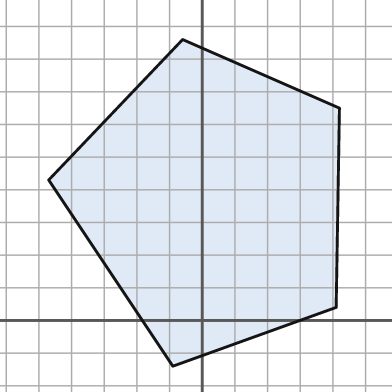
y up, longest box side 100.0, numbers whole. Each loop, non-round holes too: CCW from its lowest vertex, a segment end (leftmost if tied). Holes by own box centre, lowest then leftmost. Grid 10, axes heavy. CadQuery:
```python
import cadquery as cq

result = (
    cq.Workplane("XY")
    .moveTo(-9.0, -14.0)
    .lineTo(41.0, 4.0)
    .lineTo(42.0, 65.0)
    .lineTo(-6.0, 86.0)
    .lineTo(-47.0, 43.0)
    .close()
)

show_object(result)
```